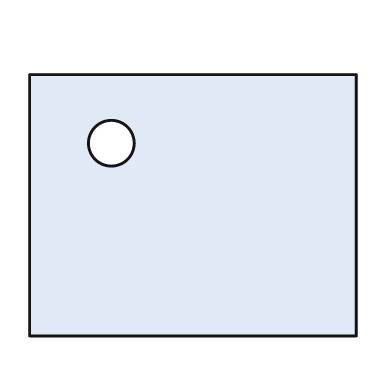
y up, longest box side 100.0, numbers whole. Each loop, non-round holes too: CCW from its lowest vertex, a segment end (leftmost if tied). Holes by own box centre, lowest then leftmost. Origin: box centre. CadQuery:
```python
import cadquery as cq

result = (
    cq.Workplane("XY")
    .moveTo(-50.0, -40.0)
    .lineTo(50.0, -40.0)
    .lineTo(50.0, 40.0)
    .lineTo(-50.0, 40.0)
    .close()
    .moveTo(-25.0, 19.0)
    .circle(7.0)
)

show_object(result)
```